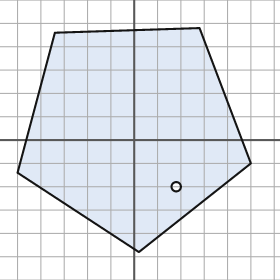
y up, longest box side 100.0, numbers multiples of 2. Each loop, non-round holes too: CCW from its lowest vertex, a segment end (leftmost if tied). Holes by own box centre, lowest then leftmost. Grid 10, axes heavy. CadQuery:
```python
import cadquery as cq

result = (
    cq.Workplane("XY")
    .moveTo(2.0, -48.0)
    .lineTo(50.0, -10.0)
    .lineTo(28.0, 48.0)
    .lineTo(-34.0, 46.0)
    .lineTo(-50.0, -14.0)
    .close()
    .moveTo(18.0, -20.0)
    .circle(2.0)
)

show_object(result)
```